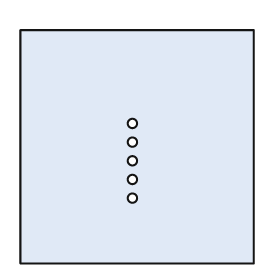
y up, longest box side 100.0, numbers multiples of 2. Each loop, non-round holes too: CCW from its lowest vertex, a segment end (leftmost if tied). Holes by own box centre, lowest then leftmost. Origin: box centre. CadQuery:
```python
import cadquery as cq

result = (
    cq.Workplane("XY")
    .moveTo(-50.0, -50.0)
    .lineTo(50.0, -50.0)
    .lineTo(50.0, 50.0)
    .lineTo(-50.0, 50.0)
    .close()
    .moveTo(-2.0, -22.0)
    .circle(2.0)
    .moveTo(-2.0, -14.0)
    .circle(2.0)
    .moveTo(-2.0, -6.0)
    .circle(2.0)
    .moveTo(-2.0, 2.0)
    .circle(2.0)
    .moveTo(-2.0, 10.0)
    .circle(2.0)
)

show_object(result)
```